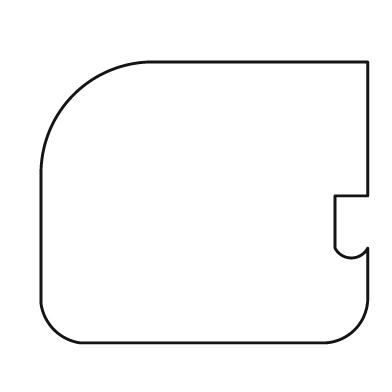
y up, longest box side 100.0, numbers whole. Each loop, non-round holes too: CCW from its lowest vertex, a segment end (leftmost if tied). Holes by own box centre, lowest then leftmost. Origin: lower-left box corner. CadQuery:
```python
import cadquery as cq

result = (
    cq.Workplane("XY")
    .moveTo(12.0, 0.0)
    .lineTo(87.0, 0.0)
    .threePointArc((96.0, 4.0), (100.0, 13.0))
    .lineTo(100.0, 29.0)
    .threePointArc((95.0, 26.0), (90.0, 29.0))
    .lineTo(90.0, 45.0)
    .lineTo(100.0, 45.0)
    .lineTo(100.0, 86.0)
    .lineTo(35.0, 86.0)
    .threePointArc((10.0, 76.0), (0.0, 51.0))
    .lineTo(0.0, 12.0)
    .threePointArc((4.0, 4.0), (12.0, 0.0))
    .close()
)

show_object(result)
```